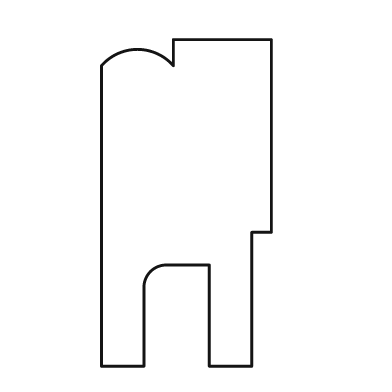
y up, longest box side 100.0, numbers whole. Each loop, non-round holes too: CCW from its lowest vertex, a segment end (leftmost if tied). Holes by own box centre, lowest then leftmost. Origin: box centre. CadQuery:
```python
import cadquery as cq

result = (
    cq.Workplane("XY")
    .moveTo(-26.0, -50.0)
    .lineTo(-13.0, -50.0)
    .lineTo(-13.0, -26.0)
    .threePointArc((-11.0, -21.0), (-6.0, -19.0))
    .lineTo(7.0, -19.0)
    .lineTo(7.0, -50.0)
    .lineTo(20.0, -50.0)
    .lineTo(20.0, -9.0)
    .lineTo(26.0, -9.0)
    .lineTo(26.0, 50.0)
    .lineTo(-4.0, 50.0)
    .lineTo(-4.0, 42.0)
    .threePointArc((-15.0, 47.0), (-26.0, 42.0))
    .close()
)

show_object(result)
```